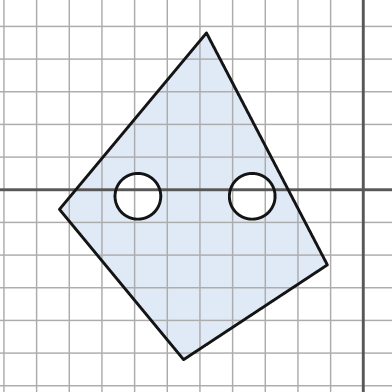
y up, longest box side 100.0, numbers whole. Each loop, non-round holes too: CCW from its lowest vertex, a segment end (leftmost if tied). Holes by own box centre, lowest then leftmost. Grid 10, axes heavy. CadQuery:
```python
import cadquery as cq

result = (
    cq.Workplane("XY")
    .moveTo(-55.0, -52.0)
    .lineTo(-11.0, -23.0)
    .lineTo(-48.0, 48.0)
    .lineTo(-93.0, -6.0)
    .close()
    .moveTo(-69.0, -2.0)
    .circle(7.0)
    .moveTo(-34.0, -2.0)
    .circle(7.0)
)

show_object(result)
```